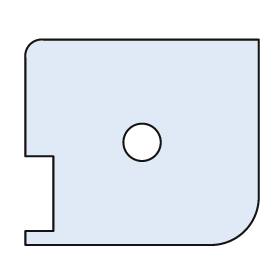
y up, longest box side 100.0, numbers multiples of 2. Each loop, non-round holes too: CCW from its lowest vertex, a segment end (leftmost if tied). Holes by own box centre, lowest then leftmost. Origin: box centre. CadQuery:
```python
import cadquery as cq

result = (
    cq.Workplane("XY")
    .moveTo(-50.0, -44.0)
    .lineTo(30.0, -44.0)
    .threePointArc((44.0, -38.0), (50.0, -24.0))
    .lineTo(50.0, 44.0)
    .lineTo(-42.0, 44.0)
    .threePointArc((-48.0, 42.0), (-50.0, 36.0))
    .lineTo(-50.0, -6.0)
    .lineTo(-38.0, -6.0)
    .lineTo(-38.0, -38.0)
    .lineTo(-50.0, -38.0)
    .close()
    .moveTo(0.0, 0.0)
    .circle(8.0)
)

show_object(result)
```